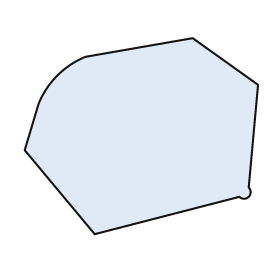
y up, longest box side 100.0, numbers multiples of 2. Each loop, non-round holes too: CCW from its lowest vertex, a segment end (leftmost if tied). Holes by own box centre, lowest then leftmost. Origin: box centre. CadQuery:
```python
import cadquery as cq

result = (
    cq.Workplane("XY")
    .moveTo(-20.0, -42.0)
    .lineTo(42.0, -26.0)
    .threePointArc((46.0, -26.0), (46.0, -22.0))
    .lineTo(50.0, 22.0)
    .lineTo(22.0, 42.0)
    .lineTo(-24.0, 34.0)
    .threePointArc((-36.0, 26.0), (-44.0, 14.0))
    .lineTo(-50.0, -6.0)
    .close()
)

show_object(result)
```